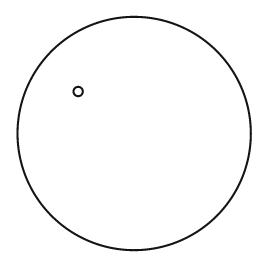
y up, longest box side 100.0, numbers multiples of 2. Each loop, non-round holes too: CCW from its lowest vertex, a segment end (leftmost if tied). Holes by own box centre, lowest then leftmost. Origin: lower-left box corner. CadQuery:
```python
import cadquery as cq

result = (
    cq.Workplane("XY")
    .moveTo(50.0, 50.0)
    .circle(50.0)
    .moveTo(26.0, 68.0)
    .circle(2.0)
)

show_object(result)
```